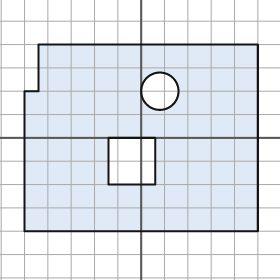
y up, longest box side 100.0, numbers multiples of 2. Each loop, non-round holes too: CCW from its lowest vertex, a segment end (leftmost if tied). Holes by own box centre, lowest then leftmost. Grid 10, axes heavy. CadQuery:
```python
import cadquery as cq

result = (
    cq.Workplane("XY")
    .moveTo(-50.0, -40.0)
    .lineTo(50.0, -40.0)
    .lineTo(50.0, 40.0)
    .lineTo(-44.0, 40.0)
    .lineTo(-44.0, 20.0)
    .lineTo(-50.0, 20.0)
    .close()
    .moveTo(-14.0, -20.0)
    .lineTo(6.0, -20.0)
    .lineTo(6.0, 0.0)
    .lineTo(-14.0, 0.0)
    .close()
    .moveTo(8.0, 20.0)
    .circle(8.0)
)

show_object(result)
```